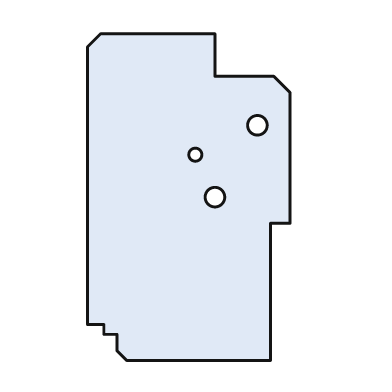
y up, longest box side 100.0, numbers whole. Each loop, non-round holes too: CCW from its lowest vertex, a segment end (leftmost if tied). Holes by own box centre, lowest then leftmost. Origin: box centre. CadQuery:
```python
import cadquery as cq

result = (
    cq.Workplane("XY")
    .moveTo(-19.0, -50.0)
    .lineTo(25.0, -50.0)
    .lineTo(25.0, -8.0)
    .lineTo(31.0, -8.0)
    .lineTo(31.0, 32.0)
    .lineTo(26.0, 37.0)
    .lineTo(8.0, 37.0)
    .lineTo(8.0, 50.0)
    .lineTo(-27.0, 50.0)
    .lineTo(-31.0, 46.0)
    .lineTo(-31.0, -39.0)
    .lineTo(-26.0, -39.0)
    .lineTo(-26.0, -42.0)
    .lineTo(-22.0, -42.0)
    .lineTo(-22.0, -47.0)
    .close()
    .moveTo(8.0, 0.0)
    .circle(3.0)
    .moveTo(2.0, 13.0)
    .circle(2.0)
    .moveTo(21.0, 22.0)
    .circle(3.0)
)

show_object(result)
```